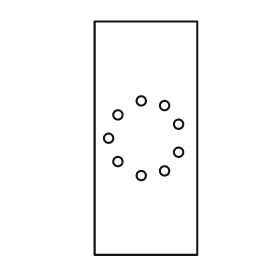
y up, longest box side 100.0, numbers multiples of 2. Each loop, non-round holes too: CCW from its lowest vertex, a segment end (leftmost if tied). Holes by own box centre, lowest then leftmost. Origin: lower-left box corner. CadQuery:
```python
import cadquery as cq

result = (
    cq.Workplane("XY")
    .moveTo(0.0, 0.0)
    .lineTo(44.0, 0.0)
    .lineTo(44.0, 100.0)
    .lineTo(0.0, 100.0)
    .close()
    .moveTo(20.0, 34.0)
    .circle(2.0)
    .moveTo(30.0, 36.0)
    .circle(2.0)
    .moveTo(10.0, 40.0)
    .circle(2.0)
    .moveTo(36.0, 44.0)
    .circle(2.0)
    .moveTo(6.0, 50.0)
    .circle(2.0)
    .moveTo(36.0, 56.0)
    .circle(2.0)
    .moveTo(10.0, 60.0)
    .circle(2.0)
    .moveTo(30.0, 64.0)
    .circle(2.0)
    .moveTo(20.0, 66.0)
    .circle(2.0)
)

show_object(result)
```